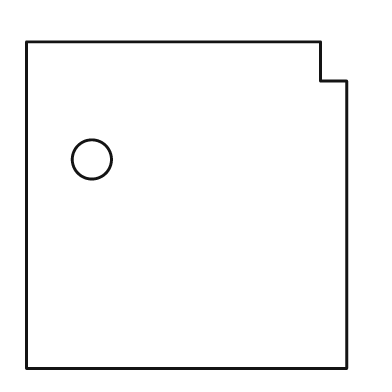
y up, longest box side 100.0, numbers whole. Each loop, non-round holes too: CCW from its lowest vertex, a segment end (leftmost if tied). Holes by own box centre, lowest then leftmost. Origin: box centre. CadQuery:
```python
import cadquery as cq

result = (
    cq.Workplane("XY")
    .moveTo(-49.0, -50.0)
    .lineTo(49.0, -50.0)
    .lineTo(49.0, 38.0)
    .lineTo(41.0, 38.0)
    .lineTo(41.0, 50.0)
    .lineTo(-49.0, 50.0)
    .close()
    .moveTo(-29.0, 14.0)
    .circle(6.0)
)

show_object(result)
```